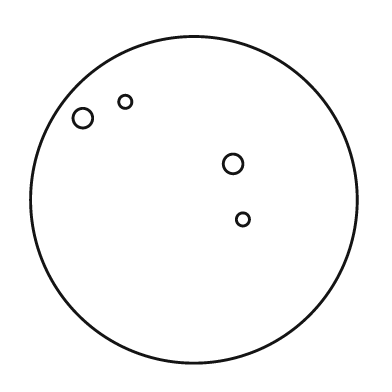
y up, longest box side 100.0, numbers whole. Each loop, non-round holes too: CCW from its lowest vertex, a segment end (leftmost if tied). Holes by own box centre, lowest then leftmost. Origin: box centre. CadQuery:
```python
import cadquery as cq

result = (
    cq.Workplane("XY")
    .moveTo(0.0, 0.0)
    .circle(50.0)
    .moveTo(15.0, -6.0)
    .circle(2.0)
    .moveTo(12.0, 11.0)
    .circle(3.0)
    .moveTo(-34.0, 25.0)
    .circle(3.0)
    .moveTo(-21.0, 30.0)
    .circle(2.0)
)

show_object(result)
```